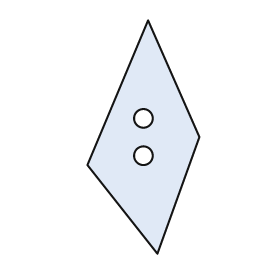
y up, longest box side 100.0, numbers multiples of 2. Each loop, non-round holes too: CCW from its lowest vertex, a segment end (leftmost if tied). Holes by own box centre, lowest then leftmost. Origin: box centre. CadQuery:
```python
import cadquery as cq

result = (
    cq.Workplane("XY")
    .moveTo(6.0, -50.0)
    .lineTo(24.0, 0.0)
    .lineTo(2.0, 50.0)
    .lineTo(-24.0, -12.0)
    .close()
    .moveTo(0.0, -8.0)
    .circle(4.0)
    .moveTo(0.0, 8.0)
    .circle(4.0)
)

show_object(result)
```